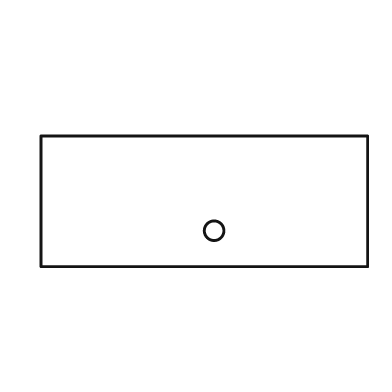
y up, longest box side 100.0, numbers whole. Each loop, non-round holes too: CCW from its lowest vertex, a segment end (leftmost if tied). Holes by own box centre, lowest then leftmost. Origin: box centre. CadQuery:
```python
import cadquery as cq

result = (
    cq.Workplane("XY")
    .moveTo(-50.0, -20.0)
    .lineTo(50.0, -20.0)
    .lineTo(50.0, 20.0)
    .lineTo(-50.0, 20.0)
    .close()
    .moveTo(3.0, -9.0)
    .circle(3.0)
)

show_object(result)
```